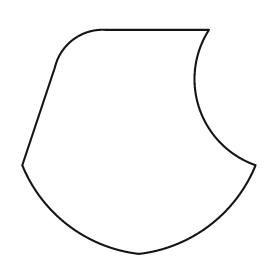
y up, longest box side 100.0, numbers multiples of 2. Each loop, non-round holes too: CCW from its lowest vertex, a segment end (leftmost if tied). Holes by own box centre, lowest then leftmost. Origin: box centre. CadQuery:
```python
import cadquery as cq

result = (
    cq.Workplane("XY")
    .moveTo(0.0, -48.0)
    .threePointArc((30.0, -36.0), (50.0, -10.0))
    .threePointArc((26.0, 14.0), (30.0, 48.0))
    .lineTo(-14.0, 48.0)
    .threePointArc((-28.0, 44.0), (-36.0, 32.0))
    .lineTo(-50.0, -10.0)
    .threePointArc((-30.0, -36.0), (0.0, -48.0))
    .close()
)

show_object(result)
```